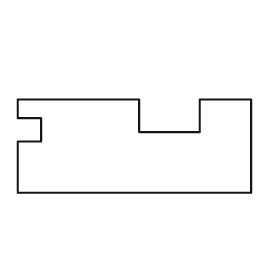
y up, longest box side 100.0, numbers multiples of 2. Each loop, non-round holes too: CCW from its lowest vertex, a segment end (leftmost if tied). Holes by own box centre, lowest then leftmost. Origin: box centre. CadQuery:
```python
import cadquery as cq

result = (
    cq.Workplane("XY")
    .moveTo(-50.0, -20.0)
    .lineTo(50.0, -20.0)
    .lineTo(50.0, 20.0)
    .lineTo(28.0, 20.0)
    .lineTo(28.0, 6.0)
    .lineTo(2.0, 6.0)
    .lineTo(2.0, 20.0)
    .lineTo(-50.0, 20.0)
    .lineTo(-50.0, 12.0)
    .lineTo(-40.0, 12.0)
    .lineTo(-40.0, 2.0)
    .lineTo(-50.0, 2.0)
    .close()
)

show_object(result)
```